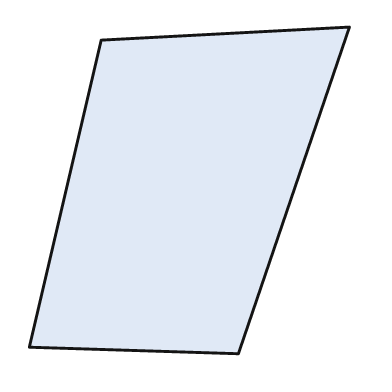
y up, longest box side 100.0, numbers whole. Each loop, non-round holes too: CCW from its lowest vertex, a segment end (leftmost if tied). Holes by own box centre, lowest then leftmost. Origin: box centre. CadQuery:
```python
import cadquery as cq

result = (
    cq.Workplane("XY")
    .moveTo(15.0, -50.0)
    .lineTo(49.0, 50.0)
    .lineTo(-27.0, 46.0)
    .lineTo(-49.0, -48.0)
    .close()
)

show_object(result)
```